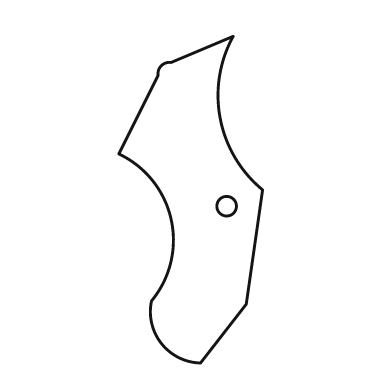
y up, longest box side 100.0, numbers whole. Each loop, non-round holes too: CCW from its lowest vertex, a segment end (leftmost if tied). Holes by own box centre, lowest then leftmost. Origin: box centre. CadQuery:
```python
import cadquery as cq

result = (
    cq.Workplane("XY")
    .moveTo(3.0, -50.0)
    .lineTo(17.0, -32.0)
    .lineTo(22.0, 3.0)
    .threePointArc((9.0, 25.0), (13.0, 50.0))
    .lineTo(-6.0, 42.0)
    .threePointArc((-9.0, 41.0), (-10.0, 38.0))
    .lineTo(-22.0, 14.0)
    .threePointArc((-6.0, -6.0), (-12.0, -31.0))
    .threePointArc((-9.0, -44.0), (3.0, -50.0))
    .close()
    .moveTo(11.0, -2.0)
    .circle(3.0)
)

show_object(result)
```